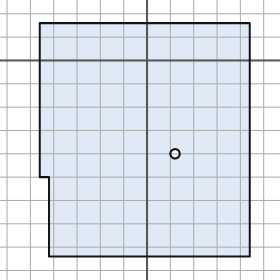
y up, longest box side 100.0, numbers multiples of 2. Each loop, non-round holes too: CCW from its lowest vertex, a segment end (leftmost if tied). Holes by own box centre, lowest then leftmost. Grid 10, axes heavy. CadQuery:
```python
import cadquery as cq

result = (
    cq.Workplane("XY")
    .moveTo(-42.0, -84.0)
    .lineTo(44.0, -84.0)
    .lineTo(44.0, 16.0)
    .lineTo(-46.0, 16.0)
    .lineTo(-46.0, -50.0)
    .lineTo(-42.0, -50.0)
    .close()
    .moveTo(12.0, -40.0)
    .circle(2.0)
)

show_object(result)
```